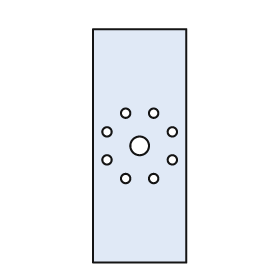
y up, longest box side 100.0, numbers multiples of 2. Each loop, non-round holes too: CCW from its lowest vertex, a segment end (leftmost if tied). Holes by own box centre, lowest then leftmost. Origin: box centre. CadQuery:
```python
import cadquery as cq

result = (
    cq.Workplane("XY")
    .moveTo(-20.0, -50.0)
    .lineTo(20.0, -50.0)
    .lineTo(20.0, 50.0)
    .lineTo(-20.0, 50.0)
    .close()
    .moveTo(-6.0, -14.0)
    .circle(2.0)
    .moveTo(6.0, -14.0)
    .circle(2.0)
    .moveTo(-14.0, -6.0)
    .circle(2.0)
    .moveTo(14.0, -6.0)
    .circle(2.0)
    .moveTo(0.0, 0.0)
    .circle(4.0)
    .moveTo(-14.0, 6.0)
    .circle(2.0)
    .moveTo(14.0, 6.0)
    .circle(2.0)
    .moveTo(-6.0, 14.0)
    .circle(2.0)
    .moveTo(6.0, 14.0)
    .circle(2.0)
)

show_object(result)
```